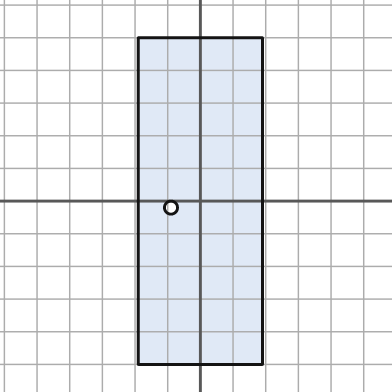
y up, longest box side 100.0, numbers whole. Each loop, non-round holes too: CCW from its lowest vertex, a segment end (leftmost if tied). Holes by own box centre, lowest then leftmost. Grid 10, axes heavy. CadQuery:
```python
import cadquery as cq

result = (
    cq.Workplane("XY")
    .moveTo(-19.0, -50.0)
    .lineTo(19.0, -50.0)
    .lineTo(19.0, 50.0)
    .lineTo(-19.0, 50.0)
    .close()
    .moveTo(-9.0, -2.0)
    .circle(2.0)
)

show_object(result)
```